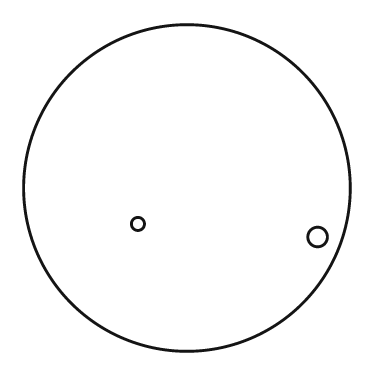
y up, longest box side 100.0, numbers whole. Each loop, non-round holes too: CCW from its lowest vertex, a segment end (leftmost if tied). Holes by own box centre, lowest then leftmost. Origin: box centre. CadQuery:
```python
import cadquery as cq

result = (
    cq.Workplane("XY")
    .moveTo(0.0, 0.0)
    .circle(50.0)
    .moveTo(40.0, -15.0)
    .circle(3.0)
    .moveTo(-15.0, -11.0)
    .circle(2.0)
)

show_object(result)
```